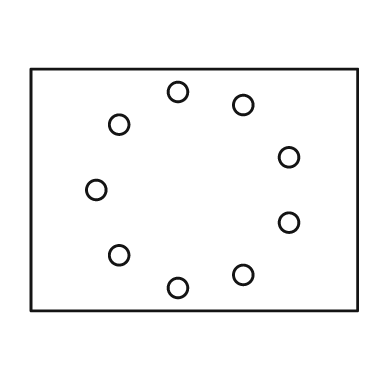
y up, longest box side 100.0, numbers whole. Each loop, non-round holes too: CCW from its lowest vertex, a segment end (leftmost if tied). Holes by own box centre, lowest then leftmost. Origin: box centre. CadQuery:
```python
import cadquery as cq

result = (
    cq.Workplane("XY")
    .moveTo(-50.0, -37.0)
    .lineTo(50.0, -37.0)
    .lineTo(50.0, 37.0)
    .lineTo(-50.0, 37.0)
    .close()
    .moveTo(-5.0, -30.0)
    .circle(3.0)
    .moveTo(15.0, -26.0)
    .circle(3.0)
    .moveTo(-23.0, -20.0)
    .circle(3.0)
    .moveTo(29.0, -10.0)
    .circle(3.0)
    .moveTo(-30.0, 0.0)
    .circle(3.0)
    .moveTo(29.0, 10.0)
    .circle(3.0)
    .moveTo(-23.0, 20.0)
    .circle(3.0)
    .moveTo(15.0, 26.0)
    .circle(3.0)
    .moveTo(-5.0, 30.0)
    .circle(3.0)
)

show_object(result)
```